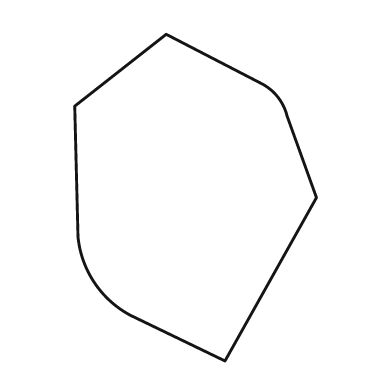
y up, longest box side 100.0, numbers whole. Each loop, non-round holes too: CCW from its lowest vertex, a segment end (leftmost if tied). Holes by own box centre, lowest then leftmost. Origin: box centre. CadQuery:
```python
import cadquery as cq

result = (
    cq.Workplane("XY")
    .moveTo(9.0, -50.0)
    .lineTo(37.0, 0.0)
    .lineTo(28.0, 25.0)
    .threePointArc((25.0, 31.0), (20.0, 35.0))
    .lineTo(-9.0, 50.0)
    .lineTo(-37.0, 28.0)
    .lineTo(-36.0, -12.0)
    .threePointArc((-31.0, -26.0), (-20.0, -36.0))
    .close()
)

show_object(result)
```